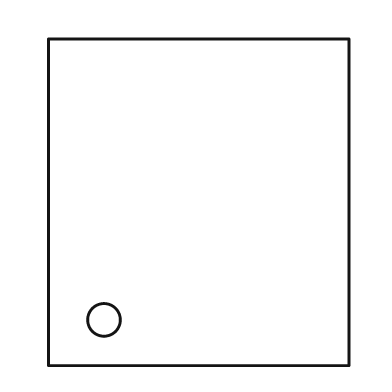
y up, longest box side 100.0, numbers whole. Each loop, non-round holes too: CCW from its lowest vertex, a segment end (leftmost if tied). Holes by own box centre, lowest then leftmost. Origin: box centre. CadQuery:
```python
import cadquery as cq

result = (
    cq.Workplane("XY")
    .moveTo(-46.0, -50.0)
    .lineTo(46.0, -50.0)
    .lineTo(46.0, 50.0)
    .lineTo(-46.0, 50.0)
    .close()
    .moveTo(-29.0, -36.0)
    .circle(5.0)
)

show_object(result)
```